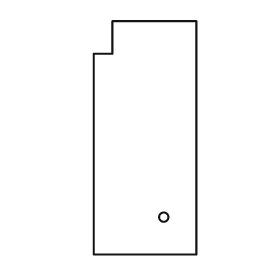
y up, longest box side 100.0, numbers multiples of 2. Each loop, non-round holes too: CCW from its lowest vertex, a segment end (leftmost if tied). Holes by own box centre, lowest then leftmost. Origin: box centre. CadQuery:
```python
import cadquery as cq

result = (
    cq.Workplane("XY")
    .moveTo(-22.0, -50.0)
    .lineTo(22.0, -50.0)
    .lineTo(22.0, 50.0)
    .lineTo(-14.0, 50.0)
    .lineTo(-14.0, 36.0)
    .lineTo(-22.0, 36.0)
    .close()
    .moveTo(8.0, -34.0)
    .circle(2.0)
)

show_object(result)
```